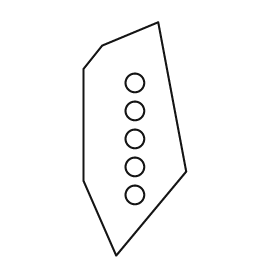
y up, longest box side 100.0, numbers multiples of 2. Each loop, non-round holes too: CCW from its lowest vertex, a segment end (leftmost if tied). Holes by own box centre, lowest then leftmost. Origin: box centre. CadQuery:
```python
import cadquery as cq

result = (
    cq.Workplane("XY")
    .moveTo(-8.0, -50.0)
    .lineTo(22.0, -14.0)
    .lineTo(10.0, 50.0)
    .lineTo(-14.0, 40.0)
    .lineTo(-22.0, 30.0)
    .lineTo(-22.0, -18.0)
    .close()
    .moveTo(0.0, -24.0)
    .circle(4.0)
    .moveTo(0.0, -12.0)
    .circle(4.0)
    .moveTo(0.0, 0.0)
    .circle(4.0)
    .moveTo(0.0, 12.0)
    .circle(4.0)
    .moveTo(0.0, 24.0)
    .circle(4.0)
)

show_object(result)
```